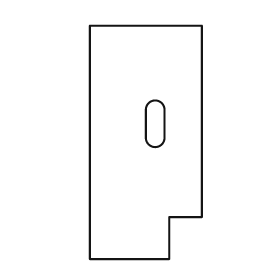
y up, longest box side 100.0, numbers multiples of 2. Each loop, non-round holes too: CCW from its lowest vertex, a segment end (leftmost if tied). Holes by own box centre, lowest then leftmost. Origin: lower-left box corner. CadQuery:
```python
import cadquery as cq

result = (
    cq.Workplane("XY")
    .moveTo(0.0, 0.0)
    .lineTo(34.0, 0.0)
    .lineTo(34.0, 18.0)
    .lineTo(48.0, 18.0)
    .lineTo(48.0, 100.0)
    .lineTo(0.0, 100.0)
    .close()
    .moveTo(24.0, 52.0)
    .threePointArc((28.0, 48.0), (32.0, 52.0))
    .lineTo(32.0, 64.0)
    .threePointArc((28.0, 68.0), (24.0, 64.0))
    .close()
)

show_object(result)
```